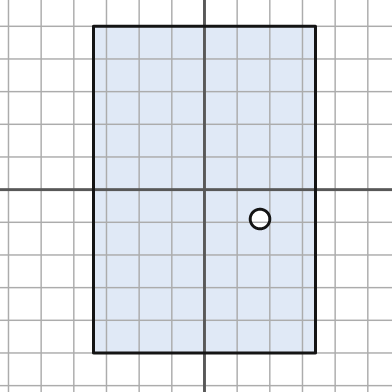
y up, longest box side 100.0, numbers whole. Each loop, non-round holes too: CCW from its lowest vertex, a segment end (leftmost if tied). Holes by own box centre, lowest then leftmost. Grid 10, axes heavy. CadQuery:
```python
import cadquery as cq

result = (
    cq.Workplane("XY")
    .moveTo(-34.0, -50.0)
    .lineTo(34.0, -50.0)
    .lineTo(34.0, 50.0)
    .lineTo(-34.0, 50.0)
    .close()
    .moveTo(17.0, -9.0)
    .circle(3.0)
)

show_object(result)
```